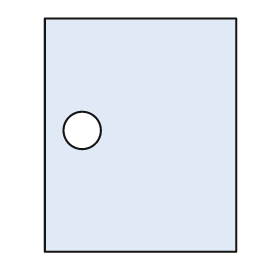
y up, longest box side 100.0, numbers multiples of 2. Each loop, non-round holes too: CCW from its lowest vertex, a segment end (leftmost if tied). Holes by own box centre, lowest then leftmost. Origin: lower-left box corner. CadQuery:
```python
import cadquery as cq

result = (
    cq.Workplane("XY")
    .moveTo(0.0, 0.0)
    .lineTo(82.0, 0.0)
    .lineTo(82.0, 100.0)
    .lineTo(0.0, 100.0)
    .close()
    .moveTo(16.0, 52.0)
    .circle(8.0)
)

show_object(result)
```